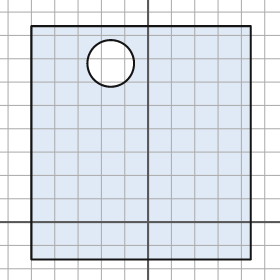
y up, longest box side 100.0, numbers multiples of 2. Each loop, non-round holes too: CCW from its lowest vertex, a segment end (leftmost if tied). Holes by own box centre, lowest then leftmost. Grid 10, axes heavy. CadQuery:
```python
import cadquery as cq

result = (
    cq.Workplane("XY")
    .moveTo(-50.0, -16.0)
    .lineTo(44.0, -16.0)
    .lineTo(44.0, 84.0)
    .lineTo(-50.0, 84.0)
    .close()
    .moveTo(-16.0, 68.0)
    .circle(10.0)
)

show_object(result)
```